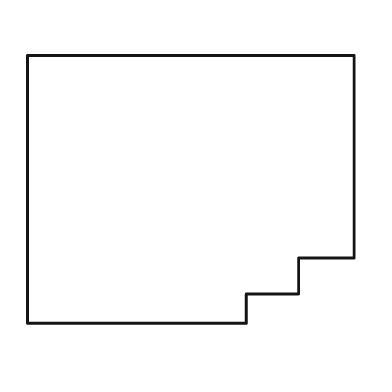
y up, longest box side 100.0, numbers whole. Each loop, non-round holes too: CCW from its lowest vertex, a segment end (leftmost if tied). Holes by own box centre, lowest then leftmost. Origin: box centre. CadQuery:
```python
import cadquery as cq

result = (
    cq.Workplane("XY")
    .moveTo(-50.0, -41.0)
    .lineTo(17.0, -41.0)
    .lineTo(17.0, -32.0)
    .lineTo(33.0, -32.0)
    .lineTo(33.0, -21.0)
    .lineTo(50.0, -21.0)
    .lineTo(50.0, 41.0)
    .lineTo(-50.0, 41.0)
    .close()
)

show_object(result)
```